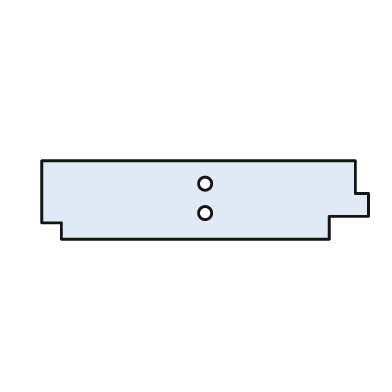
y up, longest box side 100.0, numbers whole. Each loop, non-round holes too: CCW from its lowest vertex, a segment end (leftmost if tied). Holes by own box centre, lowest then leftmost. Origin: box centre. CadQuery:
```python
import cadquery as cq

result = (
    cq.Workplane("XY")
    .moveTo(-44.0, -12.0)
    .lineTo(38.0, -12.0)
    .lineTo(38.0, -5.0)
    .lineTo(50.0, -5.0)
    .lineTo(50.0, 2.0)
    .lineTo(46.0, 2.0)
    .lineTo(46.0, 12.0)
    .lineTo(-50.0, 12.0)
    .lineTo(-50.0, -7.0)
    .lineTo(-44.0, -7.0)
    .close()
    .moveTo(0.0, -4.0)
    .circle(2.0)
    .moveTo(0.0, 5.0)
    .circle(2.0)
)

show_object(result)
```